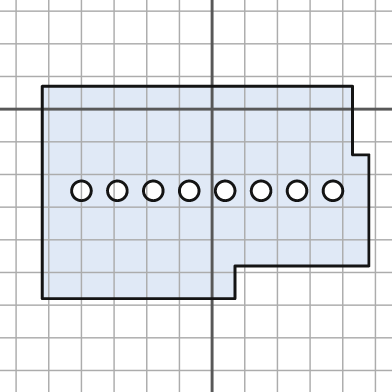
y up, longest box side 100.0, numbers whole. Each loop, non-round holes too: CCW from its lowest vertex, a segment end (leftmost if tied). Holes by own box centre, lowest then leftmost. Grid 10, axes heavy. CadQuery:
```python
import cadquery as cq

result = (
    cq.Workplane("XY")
    .moveTo(-52.0, -58.0)
    .lineTo(7.0, -58.0)
    .lineTo(7.0, -48.0)
    .lineTo(48.0, -48.0)
    .lineTo(48.0, -14.0)
    .lineTo(43.0, -14.0)
    .lineTo(43.0, 7.0)
    .lineTo(-52.0, 7.0)
    .close()
    .moveTo(-40.0, -25.0)
    .circle(3.0)
    .moveTo(-29.0, -25.0)
    .circle(3.0)
    .moveTo(-18.0, -25.0)
    .circle(3.0)
    .moveTo(-7.0, -25.0)
    .circle(3.0)
    .moveTo(4.0, -25.0)
    .circle(3.0)
    .moveTo(15.0, -25.0)
    .circle(3.0)
    .moveTo(26.0, -25.0)
    .circle(3.0)
    .moveTo(37.0, -25.0)
    .circle(3.0)
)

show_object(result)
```